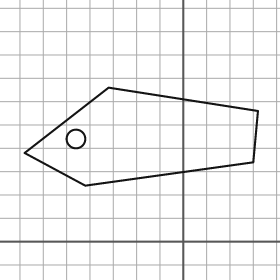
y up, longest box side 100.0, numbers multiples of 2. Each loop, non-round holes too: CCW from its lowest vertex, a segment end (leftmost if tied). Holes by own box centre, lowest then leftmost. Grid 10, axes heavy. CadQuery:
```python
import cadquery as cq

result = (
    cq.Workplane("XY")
    .moveTo(-42.0, 24.0)
    .lineTo(30.0, 34.0)
    .lineTo(32.0, 56.0)
    .lineTo(-32.0, 66.0)
    .lineTo(-68.0, 38.0)
    .close()
    .moveTo(-46.0, 44.0)
    .circle(4.0)
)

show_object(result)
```